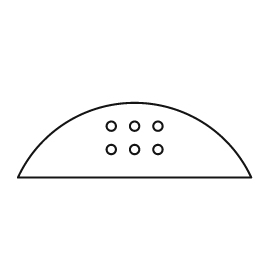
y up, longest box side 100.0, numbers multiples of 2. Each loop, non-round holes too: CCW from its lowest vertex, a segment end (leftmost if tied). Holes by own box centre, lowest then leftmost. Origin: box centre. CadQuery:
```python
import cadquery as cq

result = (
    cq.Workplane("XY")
    .moveTo(-50.0, -16.0)
    .lineTo(50.0, -16.0)
    .threePointArc((0.0, 16.0), (-50.0, -16.0))
    .close()
    .moveTo(-10.0, -4.0)
    .circle(2.0)
    .moveTo(0.0, -4.0)
    .circle(2.0)
    .moveTo(10.0, -4.0)
    .circle(2.0)
    .moveTo(-10.0, 6.0)
    .circle(2.0)
    .moveTo(0.0, 6.0)
    .circle(2.0)
    .moveTo(10.0, 6.0)
    .circle(2.0)
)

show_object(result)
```